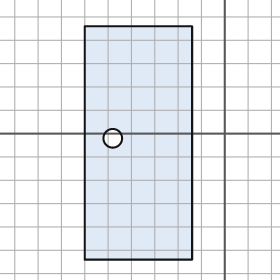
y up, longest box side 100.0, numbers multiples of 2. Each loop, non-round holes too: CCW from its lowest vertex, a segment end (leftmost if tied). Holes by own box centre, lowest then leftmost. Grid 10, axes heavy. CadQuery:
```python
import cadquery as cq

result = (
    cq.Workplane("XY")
    .moveTo(-60.0, -54.0)
    .lineTo(-14.0, -54.0)
    .lineTo(-14.0, 46.0)
    .lineTo(-60.0, 46.0)
    .close()
    .moveTo(-48.0, -2.0)
    .circle(4.0)
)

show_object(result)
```